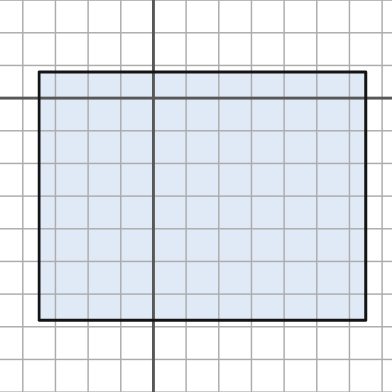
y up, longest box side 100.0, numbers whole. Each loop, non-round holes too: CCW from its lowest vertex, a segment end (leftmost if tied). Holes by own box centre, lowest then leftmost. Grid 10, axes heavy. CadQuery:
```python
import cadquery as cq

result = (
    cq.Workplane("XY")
    .moveTo(-35.0, -68.0)
    .lineTo(65.0, -68.0)
    .lineTo(65.0, 8.0)
    .lineTo(-35.0, 8.0)
    .close()
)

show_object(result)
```